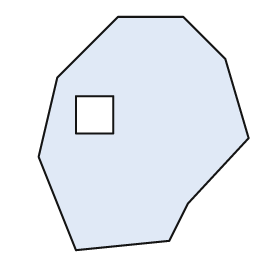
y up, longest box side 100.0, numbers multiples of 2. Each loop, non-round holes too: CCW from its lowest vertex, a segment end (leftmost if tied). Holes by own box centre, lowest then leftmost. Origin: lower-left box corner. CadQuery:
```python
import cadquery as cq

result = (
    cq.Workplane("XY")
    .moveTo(16.0, 0.0)
    .lineTo(56.0, 4.0)
    .lineTo(64.0, 20.0)
    .lineTo(90.0, 48.0)
    .lineTo(80.0, 82.0)
    .lineTo(62.0, 100.0)
    .lineTo(34.0, 100.0)
    .lineTo(8.0, 74.0)
    .lineTo(0.0, 40.0)
    .close()
    .moveTo(16.0, 50.0)
    .lineTo(32.0, 50.0)
    .lineTo(32.0, 66.0)
    .lineTo(16.0, 66.0)
    .close()
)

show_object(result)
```